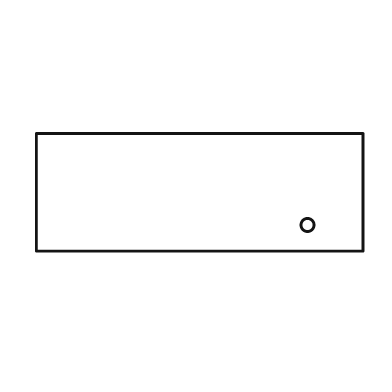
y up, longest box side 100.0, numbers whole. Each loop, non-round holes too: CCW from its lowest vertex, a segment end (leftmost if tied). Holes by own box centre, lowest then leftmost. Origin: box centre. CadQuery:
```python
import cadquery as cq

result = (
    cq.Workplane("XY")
    .moveTo(-50.0, -18.0)
    .lineTo(50.0, -18.0)
    .lineTo(50.0, 18.0)
    .lineTo(-50.0, 18.0)
    .close()
    .moveTo(33.0, -10.0)
    .circle(2.0)
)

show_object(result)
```